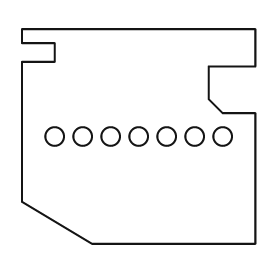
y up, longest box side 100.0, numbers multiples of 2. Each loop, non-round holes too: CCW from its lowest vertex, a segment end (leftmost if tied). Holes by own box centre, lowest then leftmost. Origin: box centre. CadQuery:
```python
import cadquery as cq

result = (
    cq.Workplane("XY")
    .moveTo(-20.0, -46.0)
    .lineTo(50.0, -46.0)
    .lineTo(50.0, 10.0)
    .lineTo(36.0, 10.0)
    .lineTo(30.0, 16.0)
    .lineTo(30.0, 30.0)
    .lineTo(50.0, 30.0)
    .lineTo(50.0, 46.0)
    .lineTo(-50.0, 46.0)
    .lineTo(-50.0, 40.0)
    .lineTo(-36.0, 40.0)
    .lineTo(-36.0, 32.0)
    .lineTo(-50.0, 32.0)
    .lineTo(-50.0, -28.0)
    .close()
    .moveTo(-36.0, 0.0)
    .circle(4.0)
    .moveTo(-24.0, 0.0)
    .circle(4.0)
    .moveTo(-12.0, 0.0)
    .circle(4.0)
    .moveTo(0.0, 0.0)
    .circle(4.0)
    .moveTo(12.0, 0.0)
    .circle(4.0)
    .moveTo(24.0, 0.0)
    .circle(4.0)
    .moveTo(36.0, 0.0)
    .circle(4.0)
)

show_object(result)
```